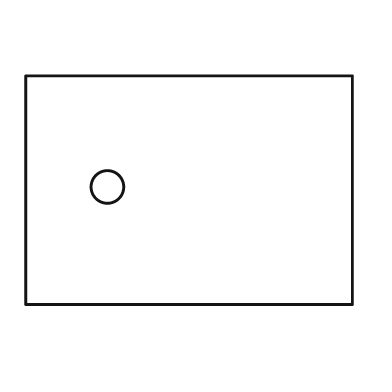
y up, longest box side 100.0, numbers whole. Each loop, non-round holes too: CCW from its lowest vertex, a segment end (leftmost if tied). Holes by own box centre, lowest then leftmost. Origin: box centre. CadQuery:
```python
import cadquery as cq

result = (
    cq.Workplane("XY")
    .moveTo(-50.0, -35.0)
    .lineTo(50.0, -35.0)
    .lineTo(50.0, 35.0)
    .lineTo(-50.0, 35.0)
    .close()
    .moveTo(-25.0, 1.0)
    .circle(5.0)
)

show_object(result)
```